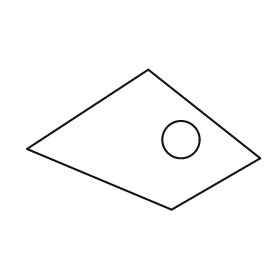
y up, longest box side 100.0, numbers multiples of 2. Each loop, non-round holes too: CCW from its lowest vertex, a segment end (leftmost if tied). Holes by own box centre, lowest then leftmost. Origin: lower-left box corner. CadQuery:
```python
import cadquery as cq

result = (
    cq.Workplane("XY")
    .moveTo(62.0, 0.0)
    .lineTo(100.0, 22.0)
    .lineTo(52.0, 60.0)
    .lineTo(0.0, 26.0)
    .close()
    .moveTo(66.0, 30.0)
    .circle(8.0)
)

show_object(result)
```